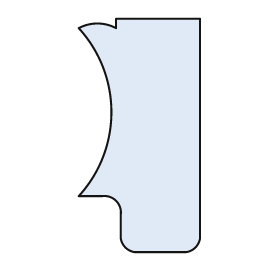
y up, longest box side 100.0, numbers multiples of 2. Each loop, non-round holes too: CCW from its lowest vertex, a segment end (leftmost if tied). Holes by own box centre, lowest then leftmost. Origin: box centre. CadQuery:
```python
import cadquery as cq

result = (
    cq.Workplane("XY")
    .moveTo(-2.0, -50.0)
    .lineTo(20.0, -50.0)
    .threePointArc((24.0, -48.0), (26.0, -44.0))
    .lineTo(26.0, 50.0)
    .lineTo(-10.0, 50.0)
    .lineTo(-10.0, 46.0)
    .threePointArc((-18.0, 48.0), (-26.0, 46.0))
    .threePointArc((-12.0, 10.0), (-26.0, -26.0))
    .lineTo(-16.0, -26.0)
    .threePointArc((-10.0, -28.0), (-8.0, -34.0))
    .lineTo(-8.0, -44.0)
    .threePointArc((-6.0, -48.0), (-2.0, -50.0))
    .close()
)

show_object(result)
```